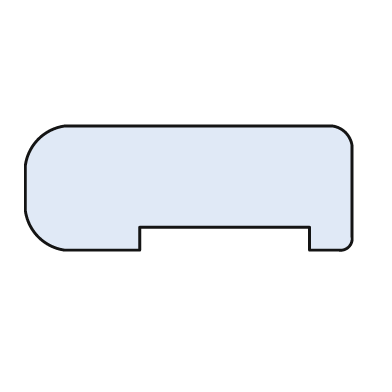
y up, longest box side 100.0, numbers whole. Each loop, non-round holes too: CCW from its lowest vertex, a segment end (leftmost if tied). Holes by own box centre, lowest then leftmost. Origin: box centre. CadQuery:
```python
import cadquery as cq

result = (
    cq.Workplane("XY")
    .moveTo(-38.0, -19.0)
    .lineTo(-15.0, -19.0)
    .lineTo(-15.0, -12.0)
    .lineTo(37.0, -12.0)
    .lineTo(37.0, -19.0)
    .lineTo(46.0, -19.0)
    .threePointArc((49.0, -18.0), (50.0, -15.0))
    .lineTo(50.0, 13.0)
    .threePointArc((48.0, 17.0), (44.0, 19.0))
    .lineTo(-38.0, 19.0)
    .threePointArc((-46.0, 15.0), (-50.0, 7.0))
    .lineTo(-50.0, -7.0)
    .threePointArc((-46.0, -15.0), (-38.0, -19.0))
    .close()
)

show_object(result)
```